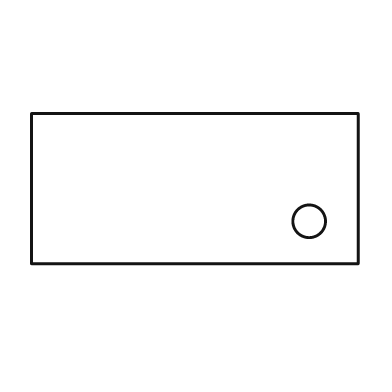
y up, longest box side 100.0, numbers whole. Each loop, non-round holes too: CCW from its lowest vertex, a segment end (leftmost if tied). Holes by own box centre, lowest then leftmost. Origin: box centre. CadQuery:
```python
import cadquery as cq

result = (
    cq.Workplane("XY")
    .moveTo(-50.0, -23.0)
    .lineTo(50.0, -23.0)
    .lineTo(50.0, 23.0)
    .lineTo(-50.0, 23.0)
    .close()
    .moveTo(35.0, -10.0)
    .circle(5.0)
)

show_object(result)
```